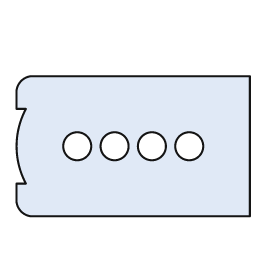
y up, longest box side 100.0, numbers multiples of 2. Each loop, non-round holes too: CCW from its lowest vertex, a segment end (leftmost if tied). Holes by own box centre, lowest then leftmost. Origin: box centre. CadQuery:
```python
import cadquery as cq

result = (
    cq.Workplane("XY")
    .moveTo(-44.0, -30.0)
    .lineTo(50.0, -30.0)
    .lineTo(50.0, 30.0)
    .lineTo(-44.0, 30.0)
    .threePointArc((-48.0, 28.0), (-50.0, 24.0))
    .lineTo(-50.0, 16.0)
    .lineTo(-46.0, 16.0)
    .threePointArc((-50.0, 0.0), (-46.0, -16.0))
    .lineTo(-50.0, -16.0)
    .lineTo(-50.0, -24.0)
    .threePointArc((-48.0, -28.0), (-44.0, -30.0))
    .close()
    .moveTo(-24.0, 0.0)
    .circle(6.0)
    .moveTo(-8.0, 0.0)
    .circle(6.0)
    .moveTo(8.0, 0.0)
    .circle(6.0)
    .moveTo(24.0, 0.0)
    .circle(6.0)
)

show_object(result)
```